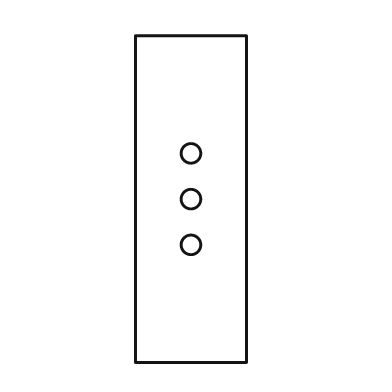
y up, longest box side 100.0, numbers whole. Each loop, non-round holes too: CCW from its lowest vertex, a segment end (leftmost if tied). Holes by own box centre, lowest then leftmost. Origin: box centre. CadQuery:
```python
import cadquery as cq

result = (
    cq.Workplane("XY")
    .moveTo(-17.0, -50.0)
    .lineTo(17.0, -50.0)
    .lineTo(17.0, 50.0)
    .lineTo(-17.0, 50.0)
    .close()
    .moveTo(0.0, -14.0)
    .circle(3.0)
    .moveTo(0.0, 0.0)
    .circle(3.0)
    .moveTo(0.0, 14.0)
    .circle(3.0)
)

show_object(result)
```